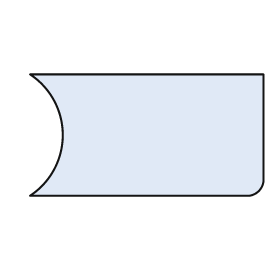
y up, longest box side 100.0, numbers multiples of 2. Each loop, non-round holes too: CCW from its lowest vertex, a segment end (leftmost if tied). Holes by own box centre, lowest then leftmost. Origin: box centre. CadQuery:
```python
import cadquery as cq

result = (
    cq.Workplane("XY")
    .moveTo(-50.0, -26.0)
    .lineTo(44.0, -26.0)
    .threePointArc((48.0, -24.0), (50.0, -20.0))
    .lineTo(50.0, 26.0)
    .lineTo(-50.0, 26.0)
    .threePointArc((-36.0, 0.0), (-50.0, -26.0))
    .close()
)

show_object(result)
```